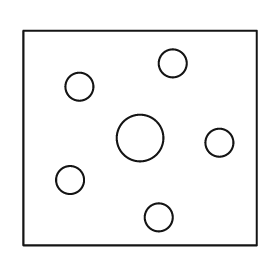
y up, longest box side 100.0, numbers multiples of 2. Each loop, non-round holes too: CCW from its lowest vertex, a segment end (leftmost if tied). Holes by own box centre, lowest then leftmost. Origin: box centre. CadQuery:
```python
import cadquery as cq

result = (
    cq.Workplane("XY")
    .moveTo(-50.0, -46.0)
    .lineTo(50.0, -46.0)
    .lineTo(50.0, 46.0)
    .lineTo(-50.0, 46.0)
    .close()
    .moveTo(8.0, -34.0)
    .circle(6.0)
    .moveTo(-30.0, -18.0)
    .circle(6.0)
    .moveTo(34.0, -2.0)
    .circle(6.0)
    .moveTo(0.0, 0.0)
    .circle(10.0)
    .moveTo(-26.0, 22.0)
    .circle(6.0)
    .moveTo(14.0, 32.0)
    .circle(6.0)
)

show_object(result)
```